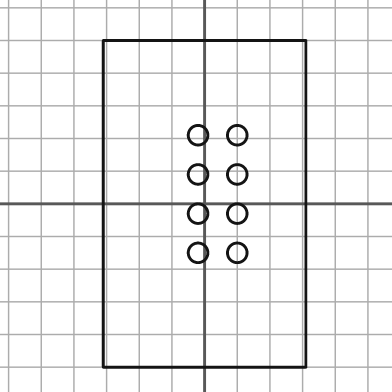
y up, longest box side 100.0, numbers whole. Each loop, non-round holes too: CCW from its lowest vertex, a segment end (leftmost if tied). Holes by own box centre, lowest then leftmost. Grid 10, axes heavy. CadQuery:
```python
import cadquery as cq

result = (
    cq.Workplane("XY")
    .moveTo(-31.0, -50.0)
    .lineTo(31.0, -50.0)
    .lineTo(31.0, 50.0)
    .lineTo(-31.0, 50.0)
    .close()
    .moveTo(-2.0, -15.0)
    .circle(3.0)
    .moveTo(10.0, -15.0)
    .circle(3.0)
    .moveTo(-2.0, -3.0)
    .circle(3.0)
    .moveTo(10.0, -3.0)
    .circle(3.0)
    .moveTo(-2.0, 9.0)
    .circle(3.0)
    .moveTo(10.0, 9.0)
    .circle(3.0)
    .moveTo(-2.0, 21.0)
    .circle(3.0)
    .moveTo(10.0, 21.0)
    .circle(3.0)
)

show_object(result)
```